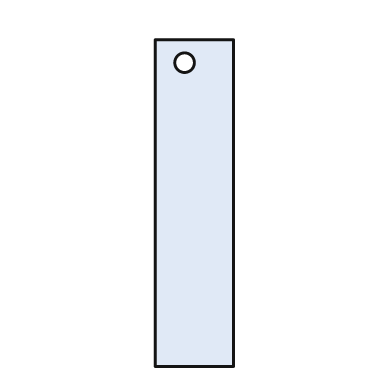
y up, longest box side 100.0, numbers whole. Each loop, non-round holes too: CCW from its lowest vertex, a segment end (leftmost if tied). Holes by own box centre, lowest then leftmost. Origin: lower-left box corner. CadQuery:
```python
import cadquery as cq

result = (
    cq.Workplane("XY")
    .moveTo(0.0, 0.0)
    .lineTo(24.0, 0.0)
    .lineTo(24.0, 100.0)
    .lineTo(0.0, 100.0)
    .close()
    .moveTo(9.0, 93.0)
    .circle(3.0)
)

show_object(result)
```